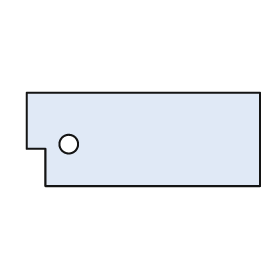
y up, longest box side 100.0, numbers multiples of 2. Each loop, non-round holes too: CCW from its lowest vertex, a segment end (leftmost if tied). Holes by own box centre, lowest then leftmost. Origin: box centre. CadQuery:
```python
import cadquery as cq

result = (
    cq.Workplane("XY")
    .moveTo(-42.0, -20.0)
    .lineTo(50.0, -20.0)
    .lineTo(50.0, 20.0)
    .lineTo(-50.0, 20.0)
    .lineTo(-50.0, -4.0)
    .lineTo(-42.0, -4.0)
    .close()
    .moveTo(-32.0, -2.0)
    .circle(4.0)
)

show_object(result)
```